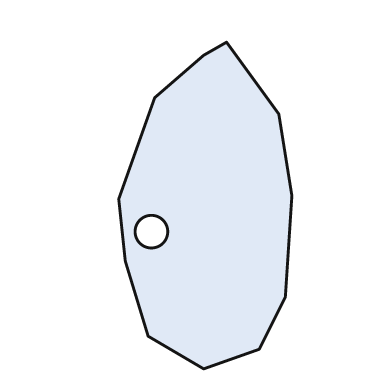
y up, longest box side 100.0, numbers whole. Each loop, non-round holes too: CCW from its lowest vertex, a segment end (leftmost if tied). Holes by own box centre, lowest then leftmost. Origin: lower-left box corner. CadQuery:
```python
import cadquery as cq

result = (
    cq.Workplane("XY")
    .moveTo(26.0, 0.0)
    .lineTo(43.0, 6.0)
    .lineTo(51.0, 22.0)
    .lineTo(53.0, 53.0)
    .lineTo(49.0, 78.0)
    .lineTo(33.0, 100.0)
    .lineTo(26.0, 96.0)
    .lineTo(11.0, 83.0)
    .lineTo(0.0, 52.0)
    .lineTo(2.0, 33.0)
    .lineTo(9.0, 10.0)
    .close()
    .moveTo(10.0, 42.0)
    .circle(5.0)
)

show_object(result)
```